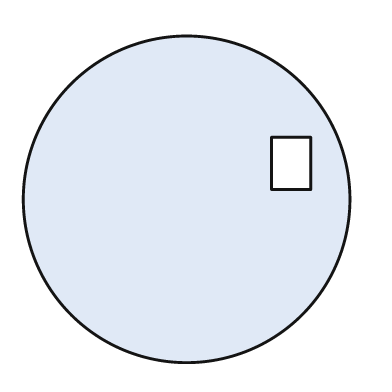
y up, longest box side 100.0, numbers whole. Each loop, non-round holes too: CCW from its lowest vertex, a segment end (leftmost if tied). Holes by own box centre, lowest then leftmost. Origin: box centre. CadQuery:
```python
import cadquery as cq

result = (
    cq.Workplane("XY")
    .moveTo(0.0, 0.0)
    .circle(50.0)
    .moveTo(26.0, 3.0)
    .lineTo(38.0, 3.0)
    .lineTo(38.0, 19.0)
    .lineTo(26.0, 19.0)
    .close()
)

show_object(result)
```